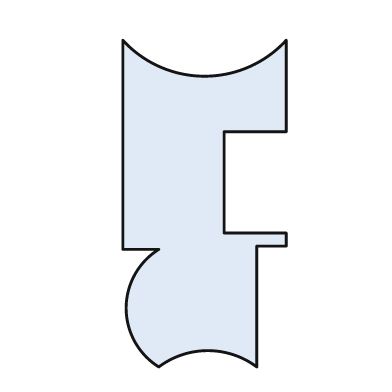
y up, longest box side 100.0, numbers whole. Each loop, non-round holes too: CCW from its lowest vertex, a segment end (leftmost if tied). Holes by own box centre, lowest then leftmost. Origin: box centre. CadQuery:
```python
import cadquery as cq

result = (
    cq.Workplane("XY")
    .moveTo(-14.0, -50.0)
    .threePointArc((1.0, -45.0), (16.0, -50.0))
    .lineTo(16.0, -13.0)
    .lineTo(25.0, -13.0)
    .lineTo(25.0, -9.0)
    .lineTo(6.0, -9.0)
    .lineTo(6.0, 22.0)
    .lineTo(25.0, 22.0)
    .lineTo(25.0, 50.0)
    .threePointArc((0.0, 39.0), (-25.0, 50.0))
    .lineTo(-25.0, -14.0)
    .lineTo(-14.0, -14.0)
    .threePointArc((-24.0, -32.0), (-14.0, -50.0))
    .close()
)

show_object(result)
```